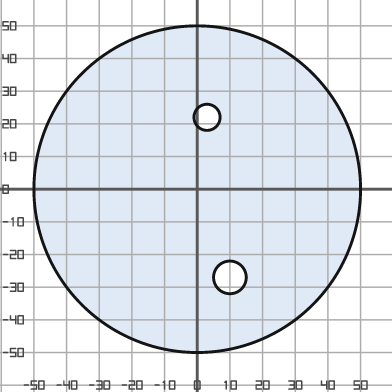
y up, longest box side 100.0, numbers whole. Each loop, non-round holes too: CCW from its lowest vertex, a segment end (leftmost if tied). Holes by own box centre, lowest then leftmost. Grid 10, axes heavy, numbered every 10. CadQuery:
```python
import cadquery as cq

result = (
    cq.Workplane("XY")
    .moveTo(0.0, 0.0)
    .circle(50.0)
    .moveTo(10.0, -27.0)
    .circle(5.0)
    .moveTo(3.0, 22.0)
    .circle(4.0)
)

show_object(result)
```